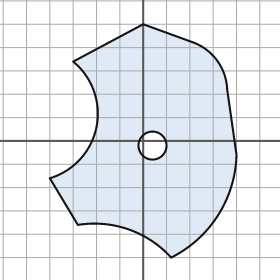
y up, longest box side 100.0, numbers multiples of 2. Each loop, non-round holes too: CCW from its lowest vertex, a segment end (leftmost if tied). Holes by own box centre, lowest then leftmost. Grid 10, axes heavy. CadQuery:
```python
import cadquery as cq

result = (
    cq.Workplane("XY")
    .moveTo(12.0, -50.0)
    .threePointArc((32.0, -32.0), (40.0, -6.0))
    .lineTo(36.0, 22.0)
    .threePointArc((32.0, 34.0), (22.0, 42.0))
    .lineTo(0.0, 50.0)
    .lineTo(-30.0, 34.0)
    .threePointArc((-20.0, 6.0), (-40.0, -16.0))
    .lineTo(-28.0, -36.0)
    .threePointArc((-6.0, -38.0), (12.0, -50.0))
    .close()
    .moveTo(4.0, -2.0)
    .circle(6.0)
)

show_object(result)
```